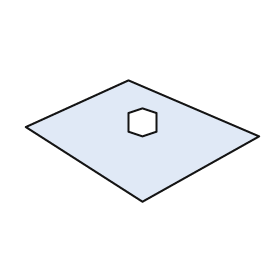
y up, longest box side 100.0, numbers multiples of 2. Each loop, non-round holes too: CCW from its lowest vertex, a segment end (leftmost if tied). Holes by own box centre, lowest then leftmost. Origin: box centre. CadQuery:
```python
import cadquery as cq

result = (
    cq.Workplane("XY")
    .moveTo(0.0, -26.0)
    .lineTo(50.0, 2.0)
    .lineTo(-6.0, 26.0)
    .lineTo(-50.0, 6.0)
    .close()
    .moveTo(0.0, 2.0)
    .lineTo(6.0, 4.0)
    .lineTo(6.0, 12.0)
    .lineTo(0.0, 14.0)
    .lineTo(-6.0, 12.0)
    .lineTo(-6.0, 4.0)
    .close()
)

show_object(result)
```